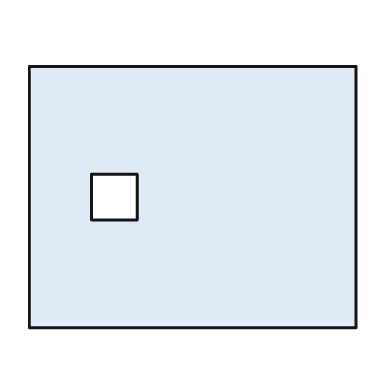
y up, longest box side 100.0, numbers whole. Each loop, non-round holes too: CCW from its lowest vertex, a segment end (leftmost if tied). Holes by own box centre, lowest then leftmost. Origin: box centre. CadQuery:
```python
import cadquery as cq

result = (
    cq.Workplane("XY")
    .moveTo(-50.0, -40.0)
    .lineTo(50.0, -40.0)
    .lineTo(50.0, 40.0)
    .lineTo(-50.0, 40.0)
    .close()
    .moveTo(-31.0, -7.0)
    .lineTo(-17.0, -7.0)
    .lineTo(-17.0, 7.0)
    .lineTo(-31.0, 7.0)
    .close()
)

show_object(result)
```